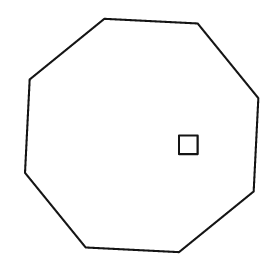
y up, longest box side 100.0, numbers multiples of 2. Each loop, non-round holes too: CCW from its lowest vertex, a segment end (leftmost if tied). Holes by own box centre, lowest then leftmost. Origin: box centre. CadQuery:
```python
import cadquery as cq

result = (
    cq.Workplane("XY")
    .moveTo(16.0, -50.0)
    .lineTo(48.0, -24.0)
    .lineTo(50.0, 16.0)
    .lineTo(24.0, 48.0)
    .lineTo(-16.0, 50.0)
    .lineTo(-48.0, 24.0)
    .lineTo(-50.0, -16.0)
    .lineTo(-24.0, -48.0)
    .close()
    .moveTo(16.0, -8.0)
    .lineTo(24.0, -8.0)
    .lineTo(24.0, 0.0)
    .lineTo(16.0, 0.0)
    .close()
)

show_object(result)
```